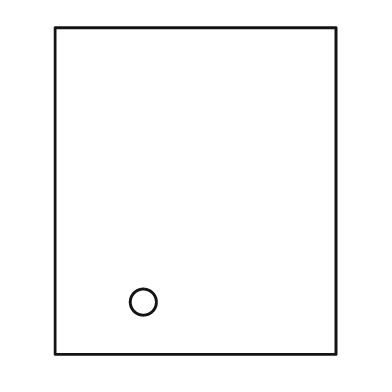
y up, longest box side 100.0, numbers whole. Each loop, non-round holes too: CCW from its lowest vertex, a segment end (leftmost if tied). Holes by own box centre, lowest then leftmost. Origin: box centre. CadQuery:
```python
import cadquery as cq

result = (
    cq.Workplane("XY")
    .moveTo(-43.0, -50.0)
    .lineTo(43.0, -50.0)
    .lineTo(43.0, 50.0)
    .lineTo(-43.0, 50.0)
    .close()
    .moveTo(-16.0, -34.0)
    .circle(4.0)
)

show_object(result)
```